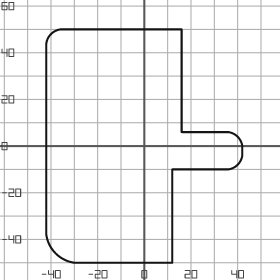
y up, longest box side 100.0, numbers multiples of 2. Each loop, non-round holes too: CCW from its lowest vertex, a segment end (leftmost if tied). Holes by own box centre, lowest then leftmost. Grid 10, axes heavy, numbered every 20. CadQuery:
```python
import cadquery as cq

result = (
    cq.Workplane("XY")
    .moveTo(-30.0, -50.0)
    .lineTo(12.0, -50.0)
    .lineTo(12.0, -10.0)
    .lineTo(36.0, -10.0)
    .threePointArc((40.0, -8.0), (42.0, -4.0))
    .lineTo(42.0, 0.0)
    .threePointArc((40.0, 4.0), (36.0, 6.0))
    .lineTo(16.0, 6.0)
    .lineTo(16.0, 50.0)
    .lineTo(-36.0, 50.0)
    .threePointArc((-40.0, 48.0), (-42.0, 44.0))
    .lineTo(-42.0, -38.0)
    .threePointArc((-38.0, -46.0), (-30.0, -50.0))
    .close()
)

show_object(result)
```